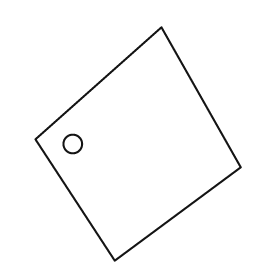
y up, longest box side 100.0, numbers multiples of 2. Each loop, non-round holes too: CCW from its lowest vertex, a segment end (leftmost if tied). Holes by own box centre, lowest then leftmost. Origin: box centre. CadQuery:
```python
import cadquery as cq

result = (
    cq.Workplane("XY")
    .moveTo(-10.0, -50.0)
    .lineTo(44.0, -10.0)
    .lineTo(10.0, 50.0)
    .lineTo(-44.0, 2.0)
    .close()
    .moveTo(-28.0, 0.0)
    .circle(4.0)
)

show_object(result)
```